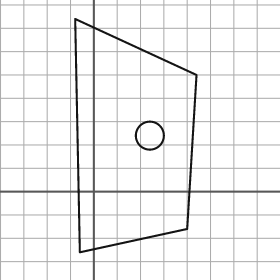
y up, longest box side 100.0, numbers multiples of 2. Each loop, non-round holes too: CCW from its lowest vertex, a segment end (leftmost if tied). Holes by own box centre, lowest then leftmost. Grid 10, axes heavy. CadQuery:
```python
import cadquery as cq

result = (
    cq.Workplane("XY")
    .moveTo(-6.0, -26.0)
    .lineTo(40.0, -16.0)
    .lineTo(44.0, 50.0)
    .lineTo(-8.0, 74.0)
    .close()
    .moveTo(24.0, 24.0)
    .circle(6.0)
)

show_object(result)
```